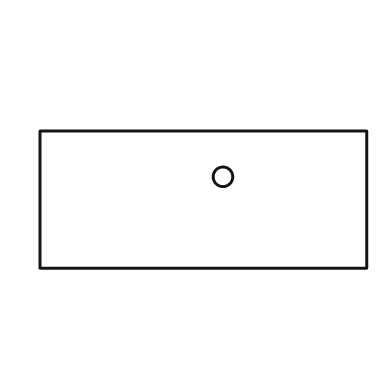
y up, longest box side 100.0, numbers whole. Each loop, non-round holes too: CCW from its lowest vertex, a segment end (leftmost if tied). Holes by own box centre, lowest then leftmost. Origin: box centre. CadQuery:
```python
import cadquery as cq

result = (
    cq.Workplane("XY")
    .moveTo(-50.0, -21.0)
    .lineTo(50.0, -21.0)
    .lineTo(50.0, 21.0)
    .lineTo(-50.0, 21.0)
    .close()
    .moveTo(6.0, 7.0)
    .circle(3.0)
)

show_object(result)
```